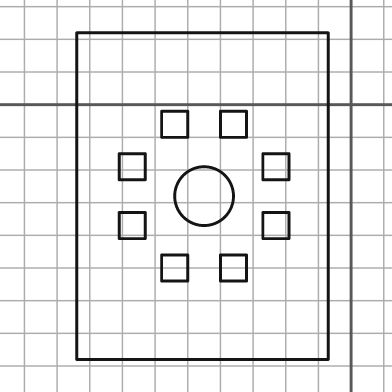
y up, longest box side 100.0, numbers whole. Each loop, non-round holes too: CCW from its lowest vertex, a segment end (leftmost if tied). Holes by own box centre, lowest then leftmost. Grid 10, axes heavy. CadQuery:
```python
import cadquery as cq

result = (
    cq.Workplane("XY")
    .moveTo(-84.0, -78.0)
    .lineTo(-7.0, -78.0)
    .lineTo(-7.0, 22.0)
    .lineTo(-84.0, 22.0)
    .close()
    .moveTo(-58.0, -54.0)
    .lineTo(-50.0, -54.0)
    .lineTo(-50.0, -46.0)
    .lineTo(-58.0, -46.0)
    .close()
    .moveTo(-40.0, -54.0)
    .lineTo(-32.0, -54.0)
    .lineTo(-32.0, -46.0)
    .lineTo(-40.0, -46.0)
    .close()
    .moveTo(-71.0, -41.0)
    .lineTo(-63.0, -41.0)
    .lineTo(-63.0, -33.0)
    .lineTo(-71.0, -33.0)
    .close()
    .moveTo(-27.0, -41.0)
    .lineTo(-19.0, -41.0)
    .lineTo(-19.0, -33.0)
    .lineTo(-27.0, -33.0)
    .close()
    .moveTo(-45.0, -28.0)
    .circle(9.0)
    .moveTo(-71.0, -23.0)
    .lineTo(-63.0, -23.0)
    .lineTo(-63.0, -15.0)
    .lineTo(-71.0, -15.0)
    .close()
    .moveTo(-27.0, -23.0)
    .lineTo(-19.0, -23.0)
    .lineTo(-19.0, -15.0)
    .lineTo(-27.0, -15.0)
    .close()
    .moveTo(-58.0, -10.0)
    .lineTo(-50.0, -10.0)
    .lineTo(-50.0, -2.0)
    .lineTo(-58.0, -2.0)
    .close()
    .moveTo(-40.0, -10.0)
    .lineTo(-32.0, -10.0)
    .lineTo(-32.0, -2.0)
    .lineTo(-40.0, -2.0)
    .close()
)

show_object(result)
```